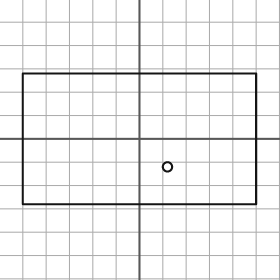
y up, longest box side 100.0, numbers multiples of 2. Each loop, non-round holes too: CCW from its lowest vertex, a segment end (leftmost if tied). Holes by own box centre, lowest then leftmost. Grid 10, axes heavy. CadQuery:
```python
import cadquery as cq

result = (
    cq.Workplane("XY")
    .moveTo(-50.0, -28.0)
    .lineTo(50.0, -28.0)
    .lineTo(50.0, 28.0)
    .lineTo(-50.0, 28.0)
    .close()
    .moveTo(12.0, -12.0)
    .circle(2.0)
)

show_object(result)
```